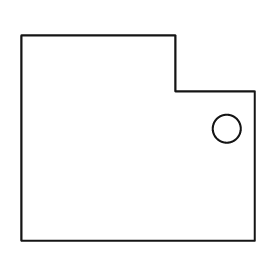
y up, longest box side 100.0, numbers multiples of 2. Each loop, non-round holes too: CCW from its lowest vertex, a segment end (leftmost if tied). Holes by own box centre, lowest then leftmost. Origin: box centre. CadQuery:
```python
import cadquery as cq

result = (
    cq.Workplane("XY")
    .moveTo(-50.0, -44.0)
    .lineTo(50.0, -44.0)
    .lineTo(50.0, 20.0)
    .lineTo(16.0, 20.0)
    .lineTo(16.0, 44.0)
    .lineTo(-50.0, 44.0)
    .close()
    .moveTo(38.0, 4.0)
    .circle(6.0)
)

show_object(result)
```